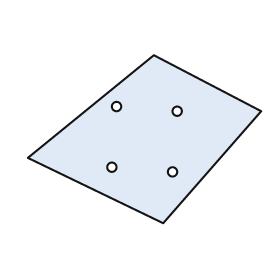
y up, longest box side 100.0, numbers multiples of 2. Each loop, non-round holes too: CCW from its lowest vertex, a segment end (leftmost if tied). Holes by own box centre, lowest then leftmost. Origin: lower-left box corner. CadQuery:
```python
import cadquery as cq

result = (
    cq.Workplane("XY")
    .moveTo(58.0, 0.0)
    .lineTo(100.0, 48.0)
    .lineTo(54.0, 72.0)
    .lineTo(0.0, 28.0)
    .close()
    .moveTo(62.0, 22.0)
    .circle(2.0)
    .moveTo(36.0, 24.0)
    .circle(2.0)
    .moveTo(64.0, 48.0)
    .circle(2.0)
    .moveTo(38.0, 50.0)
    .circle(2.0)
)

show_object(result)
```